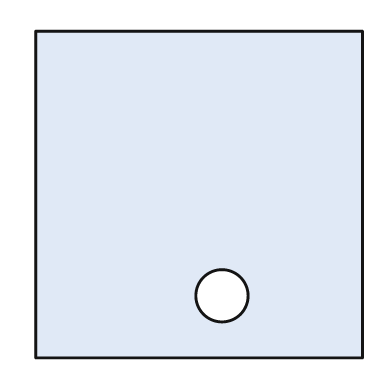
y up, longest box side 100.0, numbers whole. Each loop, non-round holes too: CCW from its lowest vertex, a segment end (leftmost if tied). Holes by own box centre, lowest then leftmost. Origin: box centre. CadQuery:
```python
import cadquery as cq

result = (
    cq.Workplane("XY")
    .moveTo(-50.0, -50.0)
    .lineTo(50.0, -50.0)
    .lineTo(50.0, 50.0)
    .lineTo(-50.0, 50.0)
    .close()
    .moveTo(7.0, -31.0)
    .circle(8.0)
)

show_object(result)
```